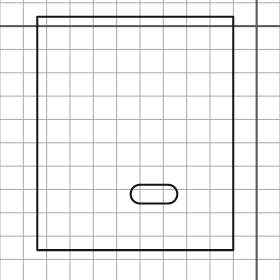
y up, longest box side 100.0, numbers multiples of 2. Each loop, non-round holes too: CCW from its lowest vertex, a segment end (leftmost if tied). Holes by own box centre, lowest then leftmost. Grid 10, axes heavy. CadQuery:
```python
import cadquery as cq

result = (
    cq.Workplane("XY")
    .moveTo(-94.0, -96.0)
    .lineTo(-10.0, -96.0)
    .lineTo(-10.0, 4.0)
    .lineTo(-94.0, 4.0)
    .close()
    .moveTo(-50.0, -76.0)
    .lineTo(-38.0, -76.0)
    .threePointArc((-34.0, -72.0), (-38.0, -68.0))
    .lineTo(-50.0, -68.0)
    .threePointArc((-54.0, -72.0), (-50.0, -76.0))
    .close()
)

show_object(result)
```